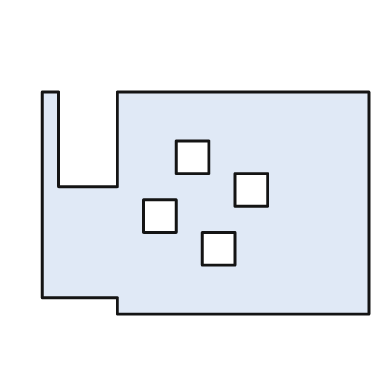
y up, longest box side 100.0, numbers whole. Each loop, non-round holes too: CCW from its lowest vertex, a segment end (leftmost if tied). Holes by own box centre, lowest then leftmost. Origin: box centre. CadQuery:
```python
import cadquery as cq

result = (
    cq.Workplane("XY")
    .moveTo(-27.0, -34.0)
    .lineTo(50.0, -34.0)
    .lineTo(50.0, 34.0)
    .lineTo(-27.0, 34.0)
    .lineTo(-27.0, 5.0)
    .lineTo(-45.0, 5.0)
    .lineTo(-45.0, 34.0)
    .lineTo(-50.0, 34.0)
    .lineTo(-50.0, -29.0)
    .lineTo(-27.0, -29.0)
    .close()
    .moveTo(-1.0, -19.0)
    .lineTo(9.0, -19.0)
    .lineTo(9.0, -9.0)
    .lineTo(-1.0, -9.0)
    .close()
    .moveTo(-19.0, -9.0)
    .lineTo(-9.0, -9.0)
    .lineTo(-9.0, 1.0)
    .lineTo(-19.0, 1.0)
    .close()
    .moveTo(9.0, -1.0)
    .lineTo(19.0, -1.0)
    .lineTo(19.0, 9.0)
    .lineTo(9.0, 9.0)
    .close()
    .moveTo(-9.0, 9.0)
    .lineTo(1.0, 9.0)
    .lineTo(1.0, 19.0)
    .lineTo(-9.0, 19.0)
    .close()
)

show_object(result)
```